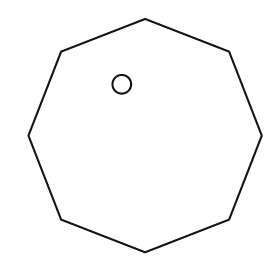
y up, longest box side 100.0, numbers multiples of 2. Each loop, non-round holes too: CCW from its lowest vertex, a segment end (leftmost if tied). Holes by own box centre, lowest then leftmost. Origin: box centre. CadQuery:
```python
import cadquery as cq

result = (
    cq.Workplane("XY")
    .moveTo(0.0, -50.0)
    .lineTo(36.0, -36.0)
    .lineTo(50.0, 0.0)
    .lineTo(36.0, 36.0)
    .lineTo(0.0, 50.0)
    .lineTo(-36.0, 36.0)
    .lineTo(-50.0, 0.0)
    .lineTo(-36.0, -36.0)
    .close()
    .moveTo(-10.0, 22.0)
    .circle(4.0)
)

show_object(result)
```